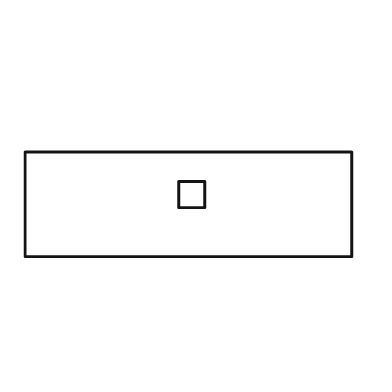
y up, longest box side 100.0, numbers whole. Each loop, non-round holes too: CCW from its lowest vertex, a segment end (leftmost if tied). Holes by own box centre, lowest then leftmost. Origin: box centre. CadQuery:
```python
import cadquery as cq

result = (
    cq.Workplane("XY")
    .moveTo(-50.0, -16.0)
    .lineTo(50.0, -16.0)
    .lineTo(50.0, 16.0)
    .lineTo(-50.0, 16.0)
    .close()
    .moveTo(-3.0, -1.0)
    .lineTo(5.0, -1.0)
    .lineTo(5.0, 7.0)
    .lineTo(-3.0, 7.0)
    .close()
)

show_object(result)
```